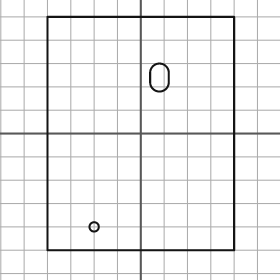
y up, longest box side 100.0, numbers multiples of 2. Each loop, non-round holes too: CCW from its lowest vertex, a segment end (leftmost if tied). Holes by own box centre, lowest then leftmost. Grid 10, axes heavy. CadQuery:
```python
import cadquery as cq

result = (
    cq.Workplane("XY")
    .moveTo(-40.0, -50.0)
    .lineTo(40.0, -50.0)
    .lineTo(40.0, 50.0)
    .lineTo(-40.0, 50.0)
    .close()
    .moveTo(-20.0, -40.0)
    .circle(2.0)
    .moveTo(4.0, 22.0)
    .threePointArc((8.0, 18.0), (12.0, 22.0))
    .lineTo(12.0, 26.0)
    .threePointArc((8.0, 30.0), (4.0, 26.0))
    .close()
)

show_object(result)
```